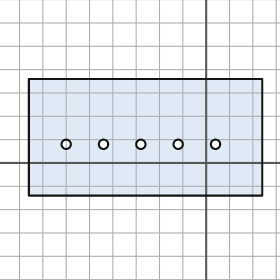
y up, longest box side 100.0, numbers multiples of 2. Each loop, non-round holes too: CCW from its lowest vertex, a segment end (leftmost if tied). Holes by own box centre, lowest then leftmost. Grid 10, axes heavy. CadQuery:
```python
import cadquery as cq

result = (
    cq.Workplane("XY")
    .moveTo(-76.0, -14.0)
    .lineTo(24.0, -14.0)
    .lineTo(24.0, 36.0)
    .lineTo(-76.0, 36.0)
    .close()
    .moveTo(-60.0, 8.0)
    .circle(2.0)
    .moveTo(-44.0, 8.0)
    .circle(2.0)
    .moveTo(-28.0, 8.0)
    .circle(2.0)
    .moveTo(-12.0, 8.0)
    .circle(2.0)
    .moveTo(4.0, 8.0)
    .circle(2.0)
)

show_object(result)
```